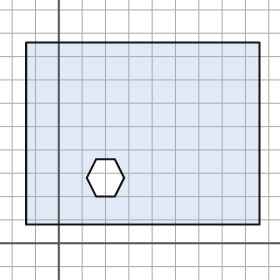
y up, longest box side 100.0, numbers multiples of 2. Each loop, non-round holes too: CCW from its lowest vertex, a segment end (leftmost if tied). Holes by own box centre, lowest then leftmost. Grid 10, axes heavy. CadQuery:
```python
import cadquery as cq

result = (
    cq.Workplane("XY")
    .moveTo(-14.0, 8.0)
    .lineTo(86.0, 8.0)
    .lineTo(86.0, 86.0)
    .lineTo(-14.0, 86.0)
    .close()
    .moveTo(16.0, 20.0)
    .lineTo(24.0, 20.0)
    .lineTo(28.0, 28.0)
    .lineTo(24.0, 36.0)
    .lineTo(16.0, 36.0)
    .lineTo(12.0, 28.0)
    .close()
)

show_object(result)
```